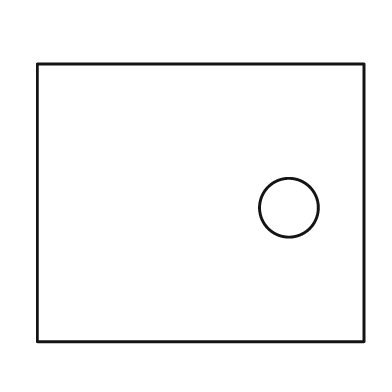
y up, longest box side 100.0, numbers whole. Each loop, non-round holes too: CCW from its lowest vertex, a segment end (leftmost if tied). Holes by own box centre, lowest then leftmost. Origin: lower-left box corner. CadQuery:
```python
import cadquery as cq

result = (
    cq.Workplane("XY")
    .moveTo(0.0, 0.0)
    .lineTo(100.0, 0.0)
    .lineTo(100.0, 85.0)
    .lineTo(0.0, 85.0)
    .close()
    .moveTo(77.0, 41.0)
    .circle(9.0)
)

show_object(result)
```